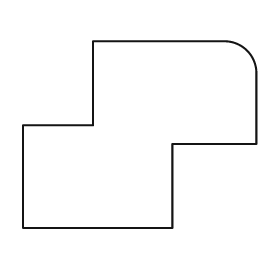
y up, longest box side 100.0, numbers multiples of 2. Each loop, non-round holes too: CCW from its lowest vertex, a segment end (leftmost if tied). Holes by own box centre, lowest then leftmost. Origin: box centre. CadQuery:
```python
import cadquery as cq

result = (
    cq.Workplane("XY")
    .moveTo(-50.0, -40.0)
    .lineTo(14.0, -40.0)
    .lineTo(14.0, -4.0)
    .lineTo(50.0, -4.0)
    .lineTo(50.0, 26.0)
    .threePointArc((46.0, 36.0), (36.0, 40.0))
    .lineTo(-20.0, 40.0)
    .lineTo(-20.0, 4.0)
    .lineTo(-50.0, 4.0)
    .close()
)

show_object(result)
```